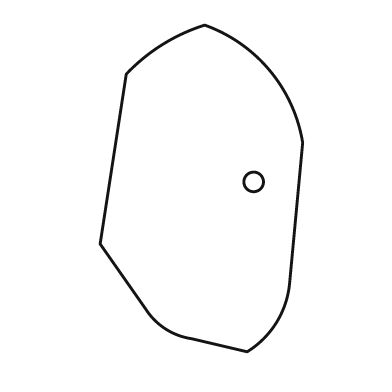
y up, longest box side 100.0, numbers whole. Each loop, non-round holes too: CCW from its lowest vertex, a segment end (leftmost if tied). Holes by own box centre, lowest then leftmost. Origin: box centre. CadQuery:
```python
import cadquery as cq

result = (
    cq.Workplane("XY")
    .moveTo(14.0, -50.0)
    .threePointArc((23.0, -41.0), (27.0, -29.0))
    .lineTo(31.0, 14.0)
    .threePointArc((21.0, 36.0), (1.0, 50.0))
    .threePointArc((-12.0, 44.0), (-23.0, 35.0))
    .lineTo(-31.0, -17.0)
    .lineTo(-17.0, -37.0)
    .threePointArc((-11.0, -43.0), (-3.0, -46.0))
    .close()
    .moveTo(16.0, 2.0)
    .circle(3.0)
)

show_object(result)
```